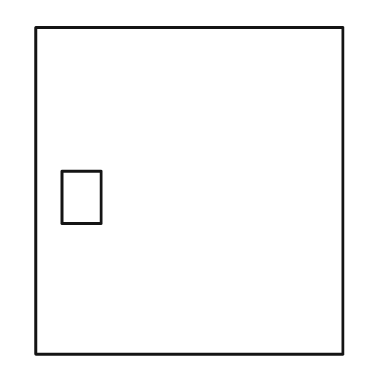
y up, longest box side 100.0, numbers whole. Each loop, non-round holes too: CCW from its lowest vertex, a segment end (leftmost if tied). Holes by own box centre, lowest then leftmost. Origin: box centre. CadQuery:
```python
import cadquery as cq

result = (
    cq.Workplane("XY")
    .moveTo(-47.0, -50.0)
    .lineTo(47.0, -50.0)
    .lineTo(47.0, 50.0)
    .lineTo(-47.0, 50.0)
    .close()
    .moveTo(-39.0, -10.0)
    .lineTo(-27.0, -10.0)
    .lineTo(-27.0, 6.0)
    .lineTo(-39.0, 6.0)
    .close()
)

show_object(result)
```